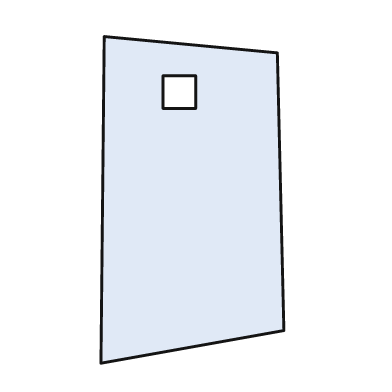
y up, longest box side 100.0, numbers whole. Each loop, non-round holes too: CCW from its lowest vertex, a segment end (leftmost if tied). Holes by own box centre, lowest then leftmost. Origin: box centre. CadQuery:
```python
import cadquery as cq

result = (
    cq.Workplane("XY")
    .moveTo(-28.0, -50.0)
    .lineTo(28.0, -40.0)
    .lineTo(26.0, 45.0)
    .lineTo(-27.0, 50.0)
    .close()
    .moveTo(-9.0, 28.0)
    .lineTo(1.0, 28.0)
    .lineTo(1.0, 38.0)
    .lineTo(-9.0, 38.0)
    .close()
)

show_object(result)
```